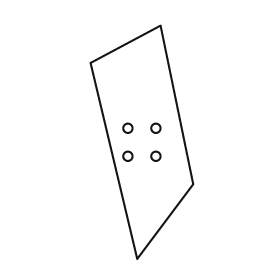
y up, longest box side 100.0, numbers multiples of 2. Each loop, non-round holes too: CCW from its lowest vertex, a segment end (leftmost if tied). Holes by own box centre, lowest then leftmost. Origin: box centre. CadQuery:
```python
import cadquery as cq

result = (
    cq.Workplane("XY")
    .moveTo(-2.0, -50.0)
    .lineTo(22.0, -18.0)
    .lineTo(8.0, 50.0)
    .lineTo(-22.0, 34.0)
    .close()
    .moveTo(-6.0, -6.0)
    .circle(2.0)
    .moveTo(6.0, -6.0)
    .circle(2.0)
    .moveTo(-6.0, 6.0)
    .circle(2.0)
    .moveTo(6.0, 6.0)
    .circle(2.0)
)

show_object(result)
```